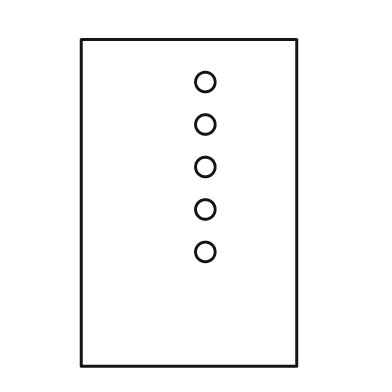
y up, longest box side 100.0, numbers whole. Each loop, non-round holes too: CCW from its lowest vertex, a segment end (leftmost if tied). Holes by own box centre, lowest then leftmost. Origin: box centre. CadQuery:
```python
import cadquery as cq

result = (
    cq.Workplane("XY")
    .moveTo(-33.0, -50.0)
    .lineTo(33.0, -50.0)
    .lineTo(33.0, 50.0)
    .lineTo(-33.0, 50.0)
    .close()
    .moveTo(5.0, -15.0)
    .circle(3.0)
    .moveTo(5.0, -2.0)
    .circle(3.0)
    .moveTo(5.0, 11.0)
    .circle(3.0)
    .moveTo(5.0, 24.0)
    .circle(3.0)
    .moveTo(5.0, 37.0)
    .circle(3.0)
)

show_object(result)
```